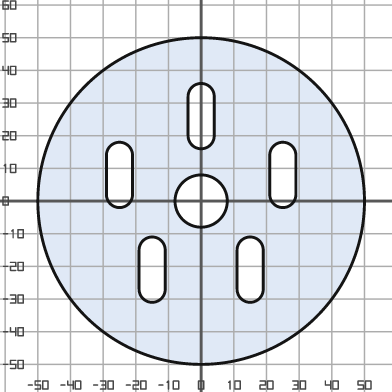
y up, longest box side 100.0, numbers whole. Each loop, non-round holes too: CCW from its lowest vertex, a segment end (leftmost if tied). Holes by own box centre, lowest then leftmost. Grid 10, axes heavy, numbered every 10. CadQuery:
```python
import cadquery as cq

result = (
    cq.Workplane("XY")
    .moveTo(0.0, 0.0)
    .circle(50.0)
    .moveTo(-19.0, -27.0)
    .threePointArc((-15.0, -31.0), (-11.0, -27.0))
    .lineTo(-11.0, -15.0)
    .threePointArc((-15.0, -11.0), (-19.0, -15.0))
    .close()
    .moveTo(11.0, -27.0)
    .threePointArc((15.0, -31.0), (19.0, -27.0))
    .lineTo(19.0, -15.0)
    .threePointArc((15.0, -11.0), (11.0, -15.0))
    .close()
    .moveTo(0.0, 0.0)
    .circle(8.0)
    .moveTo(-29.0, 2.0)
    .threePointArc((-25.0, -2.0), (-21.0, 2.0))
    .lineTo(-21.0, 14.0)
    .threePointArc((-25.0, 18.0), (-29.0, 14.0))
    .close()
    .moveTo(21.0, 2.0)
    .threePointArc((25.0, -2.0), (29.0, 2.0))
    .lineTo(29.0, 14.0)
    .threePointArc((25.0, 18.0), (21.0, 14.0))
    .close()
    .moveTo(-4.0, 20.0)
    .threePointArc((0.0, 16.0), (4.0, 20.0))
    .lineTo(4.0, 32.0)
    .threePointArc((0.0, 36.0), (-4.0, 32.0))
    .close()
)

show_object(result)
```